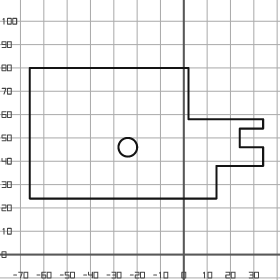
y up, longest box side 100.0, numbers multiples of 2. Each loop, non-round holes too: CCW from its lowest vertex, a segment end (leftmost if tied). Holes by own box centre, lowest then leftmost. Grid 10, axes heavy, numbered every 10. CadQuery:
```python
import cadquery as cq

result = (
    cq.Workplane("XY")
    .moveTo(-66.0, 24.0)
    .lineTo(14.0, 24.0)
    .lineTo(14.0, 38.0)
    .lineTo(34.0, 38.0)
    .lineTo(34.0, 46.0)
    .lineTo(24.0, 46.0)
    .lineTo(24.0, 54.0)
    .lineTo(34.0, 54.0)
    .lineTo(34.0, 58.0)
    .lineTo(2.0, 58.0)
    .lineTo(2.0, 80.0)
    .lineTo(-66.0, 80.0)
    .close()
    .moveTo(-24.0, 46.0)
    .circle(4.0)
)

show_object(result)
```